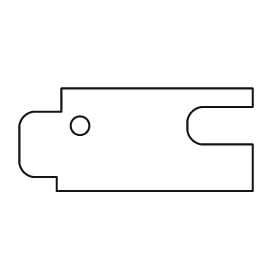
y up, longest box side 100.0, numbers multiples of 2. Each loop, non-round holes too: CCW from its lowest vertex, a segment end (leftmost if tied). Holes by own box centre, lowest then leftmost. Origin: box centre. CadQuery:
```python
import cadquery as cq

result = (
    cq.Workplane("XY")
    .moveTo(-34.0, -22.0)
    .lineTo(50.0, -22.0)
    .lineTo(50.0, -2.0)
    .lineTo(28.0, -2.0)
    .threePointArc((24.0, 0.0), (22.0, 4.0))
    .lineTo(22.0, 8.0)
    .threePointArc((24.0, 12.0), (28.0, 14.0))
    .lineTo(50.0, 14.0)
    .lineTo(50.0, 22.0)
    .lineTo(-32.0, 22.0)
    .lineTo(-32.0, 12.0)
    .lineTo(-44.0, 12.0)
    .threePointArc((-48.0, 10.0), (-50.0, 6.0))
    .lineTo(-50.0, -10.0)
    .threePointArc((-48.0, -14.0), (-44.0, -16.0))
    .lineTo(-34.0, -16.0)
    .close()
    .moveTo(-24.0, 6.0)
    .circle(4.0)
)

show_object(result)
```